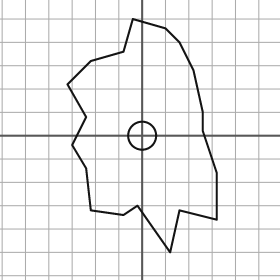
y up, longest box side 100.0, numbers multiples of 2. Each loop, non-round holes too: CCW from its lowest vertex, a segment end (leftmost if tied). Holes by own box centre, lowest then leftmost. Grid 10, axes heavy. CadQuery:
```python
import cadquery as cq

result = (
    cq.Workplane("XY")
    .moveTo(12.0, -50.0)
    .lineTo(16.0, -32.0)
    .lineTo(32.0, -36.0)
    .lineTo(32.0, -16.0)
    .lineTo(26.0, 2.0)
    .lineTo(26.0, 10.0)
    .lineTo(22.0, 28.0)
    .lineTo(16.0, 40.0)
    .lineTo(10.0, 46.0)
    .lineTo(-4.0, 50.0)
    .lineTo(-8.0, 36.0)
    .lineTo(-22.0, 32.0)
    .lineTo(-32.0, 22.0)
    .lineTo(-24.0, 8.0)
    .lineTo(-30.0, -4.0)
    .lineTo(-24.0, -14.0)
    .lineTo(-22.0, -32.0)
    .lineTo(-8.0, -34.0)
    .lineTo(-2.0, -30.0)
    .close()
    .moveTo(0.0, 0.0)
    .circle(6.0)
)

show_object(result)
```